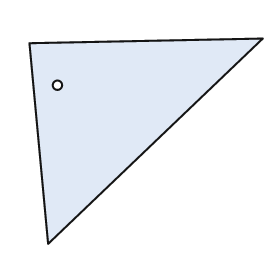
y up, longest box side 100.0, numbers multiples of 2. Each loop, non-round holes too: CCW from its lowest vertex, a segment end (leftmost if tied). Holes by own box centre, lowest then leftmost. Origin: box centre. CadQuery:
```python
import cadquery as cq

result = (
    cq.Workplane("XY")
    .moveTo(-42.0, -44.0)
    .lineTo(50.0, 44.0)
    .lineTo(-50.0, 42.0)
    .close()
    .moveTo(-38.0, 24.0)
    .circle(2.0)
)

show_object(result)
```